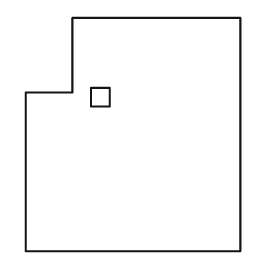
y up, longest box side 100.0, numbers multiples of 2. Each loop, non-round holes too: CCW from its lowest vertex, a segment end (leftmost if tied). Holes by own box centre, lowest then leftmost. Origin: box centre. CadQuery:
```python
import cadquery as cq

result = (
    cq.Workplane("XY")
    .moveTo(-46.0, -50.0)
    .lineTo(46.0, -50.0)
    .lineTo(46.0, 50.0)
    .lineTo(-26.0, 50.0)
    .lineTo(-26.0, 18.0)
    .lineTo(-46.0, 18.0)
    .close()
    .moveTo(-18.0, 12.0)
    .lineTo(-10.0, 12.0)
    .lineTo(-10.0, 20.0)
    .lineTo(-18.0, 20.0)
    .close()
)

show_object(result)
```